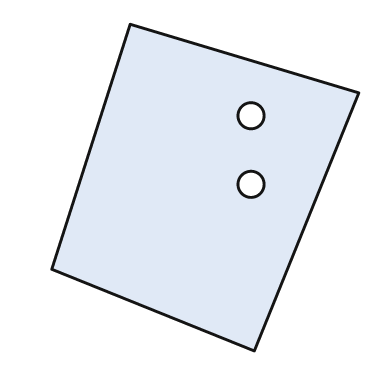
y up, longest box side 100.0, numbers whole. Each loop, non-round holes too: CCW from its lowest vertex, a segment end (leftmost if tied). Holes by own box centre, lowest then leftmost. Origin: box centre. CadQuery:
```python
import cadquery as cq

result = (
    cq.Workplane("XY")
    .moveTo(15.0, -50.0)
    .lineTo(47.0, 29.0)
    .lineTo(-23.0, 50.0)
    .lineTo(-47.0, -25.0)
    .close()
    .moveTo(14.0, 1.0)
    .circle(4.0)
    .moveTo(14.0, 22.0)
    .circle(4.0)
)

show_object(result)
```